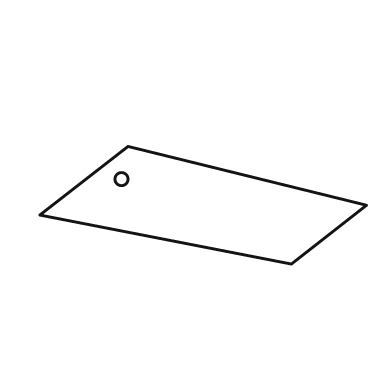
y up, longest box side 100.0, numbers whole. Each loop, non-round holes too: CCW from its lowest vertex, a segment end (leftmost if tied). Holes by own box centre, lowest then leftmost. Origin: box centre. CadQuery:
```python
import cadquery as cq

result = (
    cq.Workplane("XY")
    .moveTo(27.0, -18.0)
    .lineTo(50.0, 0.0)
    .lineTo(-23.0, 18.0)
    .lineTo(-50.0, -3.0)
    .close()
    .moveTo(-25.0, 8.0)
    .circle(2.0)
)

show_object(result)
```